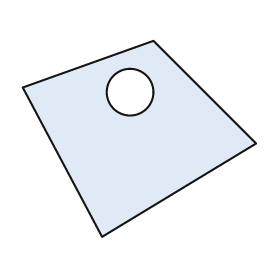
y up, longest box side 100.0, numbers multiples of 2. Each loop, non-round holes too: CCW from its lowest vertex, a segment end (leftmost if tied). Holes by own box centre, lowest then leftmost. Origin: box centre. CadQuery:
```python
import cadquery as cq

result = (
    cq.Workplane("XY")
    .moveTo(-16.0, -42.0)
    .lineTo(50.0, -2.0)
    .lineTo(6.0, 42.0)
    .lineTo(-50.0, 22.0)
    .close()
    .moveTo(-4.0, 20.0)
    .circle(10.0)
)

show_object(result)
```